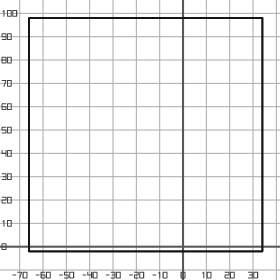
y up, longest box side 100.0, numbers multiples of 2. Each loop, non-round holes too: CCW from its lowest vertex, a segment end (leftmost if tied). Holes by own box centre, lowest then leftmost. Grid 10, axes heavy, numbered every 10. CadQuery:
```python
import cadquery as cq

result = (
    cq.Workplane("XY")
    .moveTo(-66.0, -2.0)
    .lineTo(34.0, -2.0)
    .lineTo(34.0, 98.0)
    .lineTo(-66.0, 98.0)
    .close()
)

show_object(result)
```